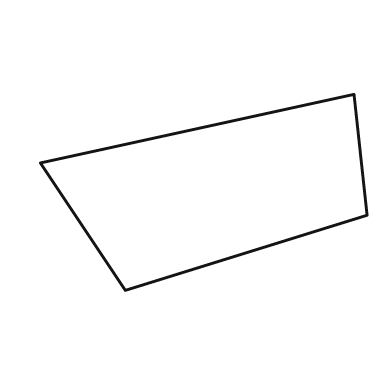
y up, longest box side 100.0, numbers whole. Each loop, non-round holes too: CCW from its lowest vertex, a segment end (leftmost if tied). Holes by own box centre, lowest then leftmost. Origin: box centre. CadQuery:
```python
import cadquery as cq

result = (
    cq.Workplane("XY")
    .moveTo(-24.0, -30.0)
    .lineTo(50.0, -7.0)
    .lineTo(46.0, 30.0)
    .lineTo(-50.0, 9.0)
    .close()
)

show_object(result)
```